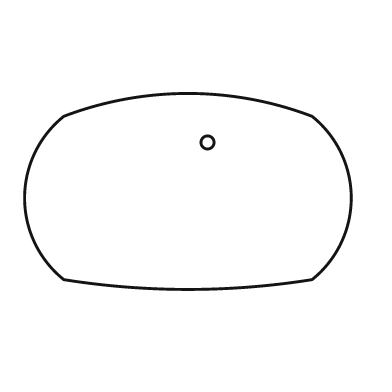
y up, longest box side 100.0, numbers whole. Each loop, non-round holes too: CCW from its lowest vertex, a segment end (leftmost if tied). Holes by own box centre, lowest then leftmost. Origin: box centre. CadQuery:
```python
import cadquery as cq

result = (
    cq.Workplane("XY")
    .moveTo(-38.0, -27.0)
    .threePointArc((0.0, -30.0), (38.0, -27.0))
    .threePointArc((50.0, -2.0), (38.0, 23.0))
    .threePointArc((0.0, 30.0), (-38.0, 23.0))
    .threePointArc((-50.0, -2.0), (-38.0, -27.0))
    .close()
    .moveTo(6.0, 15.0)
    .circle(2.0)
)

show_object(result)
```